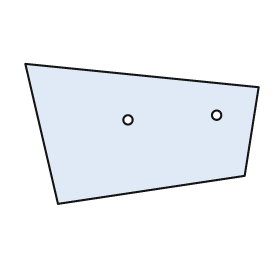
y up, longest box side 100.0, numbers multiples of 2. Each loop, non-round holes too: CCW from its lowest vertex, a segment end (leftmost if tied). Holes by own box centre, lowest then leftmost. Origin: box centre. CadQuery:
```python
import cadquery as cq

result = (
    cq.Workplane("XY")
    .moveTo(-36.0, -30.0)
    .lineTo(44.0, -18.0)
    .lineTo(50.0, 20.0)
    .lineTo(-50.0, 30.0)
    .close()
    .moveTo(-6.0, 6.0)
    .circle(2.0)
    .moveTo(32.0, 8.0)
    .circle(2.0)
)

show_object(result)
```